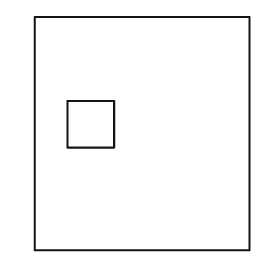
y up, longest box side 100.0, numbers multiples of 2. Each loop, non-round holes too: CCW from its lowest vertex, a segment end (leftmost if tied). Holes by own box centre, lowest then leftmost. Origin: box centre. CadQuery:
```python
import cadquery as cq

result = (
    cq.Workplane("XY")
    .moveTo(-46.0, -50.0)
    .lineTo(46.0, -50.0)
    .lineTo(46.0, 50.0)
    .lineTo(-46.0, 50.0)
    .close()
    .moveTo(-32.0, -6.0)
    .lineTo(-12.0, -6.0)
    .lineTo(-12.0, 14.0)
    .lineTo(-32.0, 14.0)
    .close()
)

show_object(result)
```